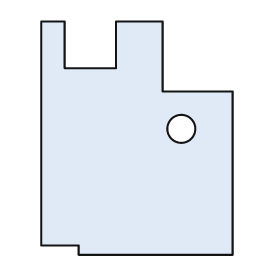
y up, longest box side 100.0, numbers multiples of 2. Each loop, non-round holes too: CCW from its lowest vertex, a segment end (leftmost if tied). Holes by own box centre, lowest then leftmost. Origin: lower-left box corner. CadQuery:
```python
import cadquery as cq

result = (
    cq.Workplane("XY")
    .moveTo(16.0, 0.0)
    .lineTo(82.0, 0.0)
    .lineTo(82.0, 70.0)
    .lineTo(52.0, 70.0)
    .lineTo(52.0, 100.0)
    .lineTo(32.0, 100.0)
    .lineTo(32.0, 80.0)
    .lineTo(10.0, 80.0)
    .lineTo(10.0, 100.0)
    .lineTo(0.0, 100.0)
    .lineTo(0.0, 4.0)
    .lineTo(16.0, 4.0)
    .close()
    .moveTo(60.0, 54.0)
    .circle(6.0)
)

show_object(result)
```